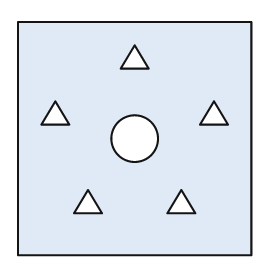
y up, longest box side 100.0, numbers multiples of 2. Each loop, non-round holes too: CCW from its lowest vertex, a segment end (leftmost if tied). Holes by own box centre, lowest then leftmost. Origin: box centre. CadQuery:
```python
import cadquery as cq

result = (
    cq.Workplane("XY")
    .moveTo(-50.0, -50.0)
    .lineTo(50.0, -50.0)
    .lineTo(50.0, 50.0)
    .lineTo(-50.0, 50.0)
    .close()
    .moveTo(-26.0, -32.0)
    .lineTo(-14.0, -32.0)
    .lineTo(-20.0, -22.0)
    .close()
    .moveTo(14.0, -32.0)
    .lineTo(26.0, -32.0)
    .lineTo(20.0, -22.0)
    .close()
    .moveTo(0.0, 0.0)
    .circle(10.0)
    .moveTo(-40.0, 6.0)
    .lineTo(-28.0, 6.0)
    .lineTo(-34.0, 16.0)
    .close()
    .moveTo(28.0, 6.0)
    .lineTo(40.0, 6.0)
    .lineTo(34.0, 16.0)
    .close()
    .moveTo(-6.0, 30.0)
    .lineTo(6.0, 30.0)
    .lineTo(0.0, 40.0)
    .close()
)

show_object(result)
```